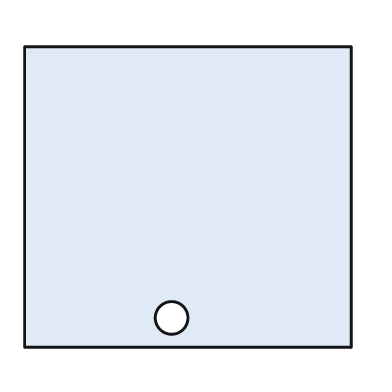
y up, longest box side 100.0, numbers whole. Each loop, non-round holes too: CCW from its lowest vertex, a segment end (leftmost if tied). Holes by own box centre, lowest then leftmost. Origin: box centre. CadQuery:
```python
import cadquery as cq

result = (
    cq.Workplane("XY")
    .moveTo(-50.0, -46.0)
    .lineTo(50.0, -46.0)
    .lineTo(50.0, 46.0)
    .lineTo(-50.0, 46.0)
    .close()
    .moveTo(-5.0, -37.0)
    .circle(5.0)
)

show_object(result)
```